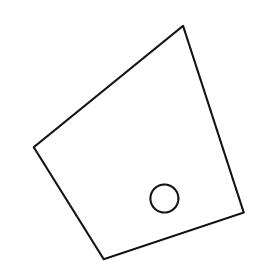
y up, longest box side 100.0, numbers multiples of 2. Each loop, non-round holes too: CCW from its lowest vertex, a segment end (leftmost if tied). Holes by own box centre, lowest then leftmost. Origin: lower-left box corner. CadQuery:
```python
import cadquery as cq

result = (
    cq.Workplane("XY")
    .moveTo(30.0, 0.0)
    .lineTo(90.0, 20.0)
    .lineTo(64.0, 100.0)
    .lineTo(0.0, 48.0)
    .close()
    .moveTo(56.0, 26.0)
    .circle(6.0)
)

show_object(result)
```